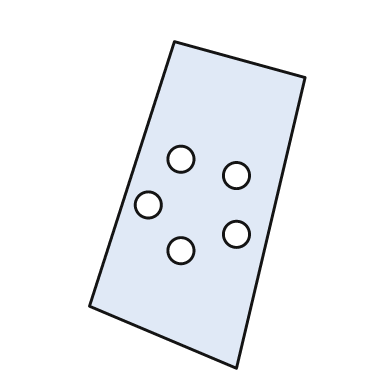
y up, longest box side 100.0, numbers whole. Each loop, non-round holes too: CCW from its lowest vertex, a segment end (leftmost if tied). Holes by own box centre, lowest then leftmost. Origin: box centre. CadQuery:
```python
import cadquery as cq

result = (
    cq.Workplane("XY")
    .moveTo(12.0, -50.0)
    .lineTo(33.0, 39.0)
    .lineTo(-7.0, 50.0)
    .lineTo(-33.0, -31.0)
    .close()
    .moveTo(-5.0, -14.0)
    .circle(4.0)
    .moveTo(12.0, -9.0)
    .circle(4.0)
    .moveTo(-15.0, 0.0)
    .circle(4.0)
    .moveTo(12.0, 9.0)
    .circle(4.0)
    .moveTo(-5.0, 14.0)
    .circle(4.0)
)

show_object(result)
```